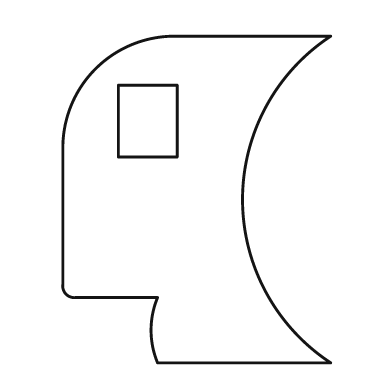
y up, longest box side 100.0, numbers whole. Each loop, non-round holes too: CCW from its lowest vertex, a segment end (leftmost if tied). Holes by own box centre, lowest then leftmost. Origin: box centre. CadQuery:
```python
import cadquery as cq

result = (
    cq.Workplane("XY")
    .moveTo(-12.0, -50.0)
    .lineTo(41.0, -50.0)
    .threePointArc((14.0, 0.0), (41.0, 50.0))
    .lineTo(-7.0, 50.0)
    .threePointArc((-31.0, 40.0), (-41.0, 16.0))
    .lineTo(-41.0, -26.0)
    .threePointArc((-40.0, -29.0), (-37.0, -30.0))
    .lineTo(-12.0, -30.0)
    .threePointArc((-14.0, -40.0), (-12.0, -50.0))
    .close()
    .moveTo(-24.0, 13.0)
    .lineTo(-6.0, 13.0)
    .lineTo(-6.0, 35.0)
    .lineTo(-24.0, 35.0)
    .close()
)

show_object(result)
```